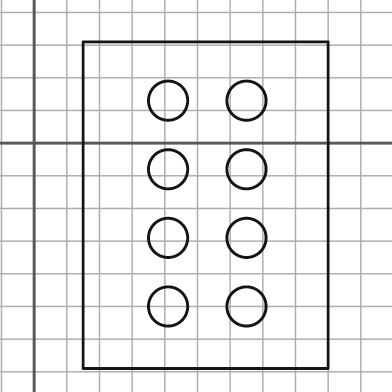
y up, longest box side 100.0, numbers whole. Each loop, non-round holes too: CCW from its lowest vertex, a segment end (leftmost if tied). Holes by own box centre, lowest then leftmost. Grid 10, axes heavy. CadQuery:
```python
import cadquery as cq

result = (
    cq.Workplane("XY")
    .moveTo(15.0, -69.0)
    .lineTo(90.0, -69.0)
    .lineTo(90.0, 31.0)
    .lineTo(15.0, 31.0)
    .close()
    .moveTo(41.0, -50.0)
    .circle(6.0)
    .moveTo(65.0, -50.0)
    .circle(6.0)
    .moveTo(41.0, -29.0)
    .circle(6.0)
    .moveTo(65.0, -29.0)
    .circle(6.0)
    .moveTo(41.0, -8.0)
    .circle(6.0)
    .moveTo(65.0, -8.0)
    .circle(6.0)
    .moveTo(41.0, 13.0)
    .circle(6.0)
    .moveTo(65.0, 13.0)
    .circle(6.0)
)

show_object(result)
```